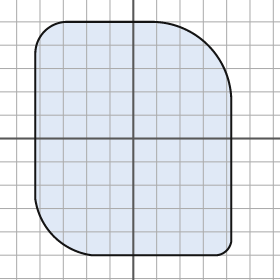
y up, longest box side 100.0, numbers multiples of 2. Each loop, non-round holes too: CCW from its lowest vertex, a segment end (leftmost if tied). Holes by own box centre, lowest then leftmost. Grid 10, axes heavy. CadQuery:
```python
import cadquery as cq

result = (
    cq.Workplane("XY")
    .moveTo(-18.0, -50.0)
    .lineTo(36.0, -50.0)
    .threePointArc((40.0, -48.0), (42.0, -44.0))
    .lineTo(42.0, 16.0)
    .threePointArc((32.0, 40.0), (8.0, 50.0))
    .lineTo(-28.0, 50.0)
    .threePointArc((-38.0, 46.0), (-42.0, 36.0))
    .lineTo(-42.0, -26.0)
    .threePointArc((-34.0, -42.0), (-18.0, -50.0))
    .close()
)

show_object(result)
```